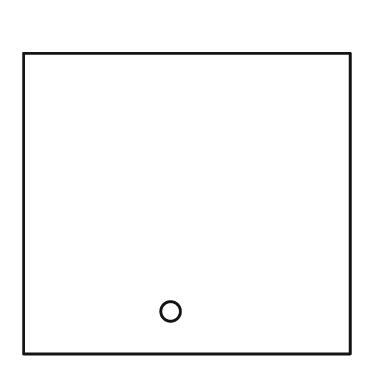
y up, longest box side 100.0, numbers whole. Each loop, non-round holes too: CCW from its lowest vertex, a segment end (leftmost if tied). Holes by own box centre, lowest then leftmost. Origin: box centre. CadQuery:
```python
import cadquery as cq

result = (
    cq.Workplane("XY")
    .moveTo(-50.0, -46.0)
    .lineTo(50.0, -46.0)
    .lineTo(50.0, 46.0)
    .lineTo(-50.0, 46.0)
    .close()
    .moveTo(-5.0, -33.0)
    .circle(3.0)
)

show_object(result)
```